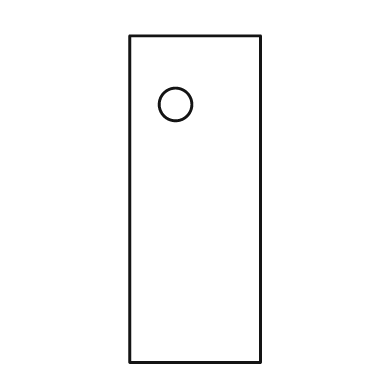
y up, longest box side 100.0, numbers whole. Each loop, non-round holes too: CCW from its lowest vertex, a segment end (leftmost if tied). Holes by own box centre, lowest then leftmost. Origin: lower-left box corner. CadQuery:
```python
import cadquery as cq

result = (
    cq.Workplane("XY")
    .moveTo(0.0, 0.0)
    .lineTo(40.0, 0.0)
    .lineTo(40.0, 100.0)
    .lineTo(0.0, 100.0)
    .close()
    .moveTo(14.0, 79.0)
    .circle(5.0)
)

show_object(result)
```